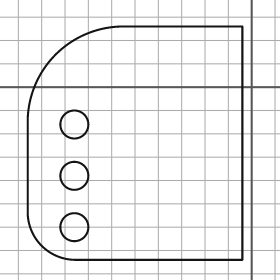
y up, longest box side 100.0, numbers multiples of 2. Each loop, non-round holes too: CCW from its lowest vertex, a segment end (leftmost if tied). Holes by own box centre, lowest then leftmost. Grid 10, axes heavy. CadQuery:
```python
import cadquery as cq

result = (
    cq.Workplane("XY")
    .moveTo(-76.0, -74.0)
    .lineTo(-4.0, -74.0)
    .lineTo(-4.0, 26.0)
    .lineTo(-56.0, 26.0)
    .threePointArc((-84.0, 14.0), (-96.0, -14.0))
    .lineTo(-96.0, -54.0)
    .threePointArc((-90.0, -68.0), (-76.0, -74.0))
    .close()
    .moveTo(-76.0, -60.0)
    .circle(6.0)
    .moveTo(-76.0, -38.0)
    .circle(6.0)
    .moveTo(-76.0, -16.0)
    .circle(6.0)
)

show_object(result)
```